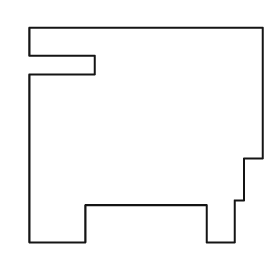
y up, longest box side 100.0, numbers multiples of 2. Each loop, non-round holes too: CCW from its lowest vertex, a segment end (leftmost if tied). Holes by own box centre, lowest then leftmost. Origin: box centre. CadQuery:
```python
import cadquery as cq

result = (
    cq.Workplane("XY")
    .moveTo(-50.0, -46.0)
    .lineTo(-26.0, -46.0)
    .lineTo(-26.0, -30.0)
    .lineTo(26.0, -30.0)
    .lineTo(26.0, -46.0)
    .lineTo(38.0, -46.0)
    .lineTo(38.0, -28.0)
    .lineTo(42.0, -28.0)
    .lineTo(42.0, -10.0)
    .lineTo(50.0, -10.0)
    .lineTo(50.0, 46.0)
    .lineTo(-50.0, 46.0)
    .lineTo(-50.0, 34.0)
    .lineTo(-22.0, 34.0)
    .lineTo(-22.0, 26.0)
    .lineTo(-50.0, 26.0)
    .close()
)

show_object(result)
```